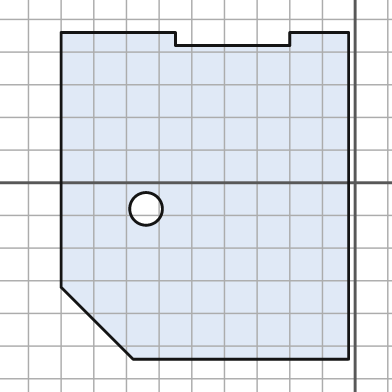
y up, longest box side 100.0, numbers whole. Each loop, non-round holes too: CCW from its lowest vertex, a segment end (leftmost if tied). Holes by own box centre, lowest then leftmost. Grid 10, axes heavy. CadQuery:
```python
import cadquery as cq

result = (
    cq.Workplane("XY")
    .moveTo(-68.0, -54.0)
    .lineTo(-2.0, -54.0)
    .lineTo(-2.0, 46.0)
    .lineTo(-20.0, 46.0)
    .lineTo(-20.0, 42.0)
    .lineTo(-55.0, 42.0)
    .lineTo(-55.0, 46.0)
    .lineTo(-90.0, 46.0)
    .lineTo(-90.0, -32.0)
    .close()
    .moveTo(-64.0, -8.0)
    .circle(5.0)
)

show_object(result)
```